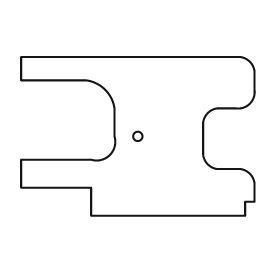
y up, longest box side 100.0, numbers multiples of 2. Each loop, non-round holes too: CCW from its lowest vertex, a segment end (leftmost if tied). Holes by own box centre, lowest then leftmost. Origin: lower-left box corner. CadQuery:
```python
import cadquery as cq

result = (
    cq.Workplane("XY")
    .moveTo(30.0, 0.0)
    .lineTo(96.0, 0.0)
    .lineTo(96.0, 6.0)
    .lineTo(100.0, 6.0)
    .lineTo(100.0, 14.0)
    .threePointArc((98.0, 18.0), (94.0, 20.0))
    .lineTo(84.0, 20.0)
    .threePointArc((80.0, 22.0), (78.0, 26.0))
    .lineTo(78.0, 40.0)
    .threePointArc((80.0, 44.0), (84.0, 46.0))
    .lineTo(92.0, 46.0)
    .threePointArc((98.0, 48.0), (100.0, 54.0))
    .lineTo(100.0, 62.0)
    .threePointArc((98.0, 66.0), (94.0, 68.0))
    .lineTo(0.0, 68.0)
    .lineTo(0.0, 58.0)
    .lineTo(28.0, 58.0)
    .threePointArc((36.0, 54.0), (40.0, 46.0))
    .lineTo(40.0, 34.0)
    .threePointArc((38.0, 26.0), (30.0, 24.0))
    .lineTo(0.0, 24.0)
    .lineTo(0.0, 12.0)
    .lineTo(30.0, 12.0)
    .close()
    .moveTo(50.0, 34.0)
    .circle(2.0)
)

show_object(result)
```